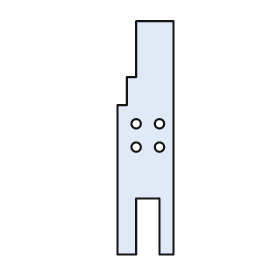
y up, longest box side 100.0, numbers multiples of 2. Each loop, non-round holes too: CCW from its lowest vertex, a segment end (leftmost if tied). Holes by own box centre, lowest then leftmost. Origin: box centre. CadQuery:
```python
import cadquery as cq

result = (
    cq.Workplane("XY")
    .moveTo(-12.0, -50.0)
    .lineTo(-4.0, -50.0)
    .lineTo(-4.0, -26.0)
    .lineTo(6.0, -26.0)
    .lineTo(6.0, -50.0)
    .lineTo(12.0, -50.0)
    .lineTo(12.0, 50.0)
    .lineTo(-4.0, 50.0)
    .lineTo(-4.0, 26.0)
    .lineTo(-8.0, 26.0)
    .lineTo(-8.0, 14.0)
    .lineTo(-12.0, 14.0)
    .close()
    .moveTo(-4.0, -4.0)
    .circle(2.0)
    .moveTo(6.0, -4.0)
    .circle(2.0)
    .moveTo(-4.0, 6.0)
    .circle(2.0)
    .moveTo(6.0, 6.0)
    .circle(2.0)
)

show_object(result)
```